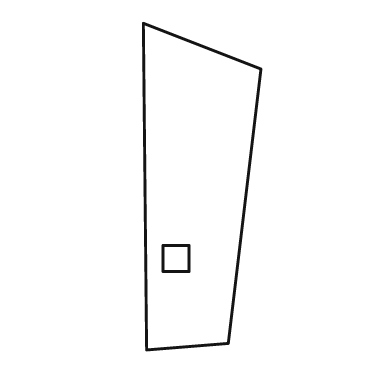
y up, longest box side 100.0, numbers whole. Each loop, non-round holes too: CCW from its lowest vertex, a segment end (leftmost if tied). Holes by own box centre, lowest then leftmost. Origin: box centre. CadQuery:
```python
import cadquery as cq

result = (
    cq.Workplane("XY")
    .moveTo(-17.0, -50.0)
    .lineTo(8.0, -48.0)
    .lineTo(18.0, 36.0)
    .lineTo(-18.0, 50.0)
    .close()
    .moveTo(-12.0, -26.0)
    .lineTo(-4.0, -26.0)
    .lineTo(-4.0, -18.0)
    .lineTo(-12.0, -18.0)
    .close()
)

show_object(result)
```